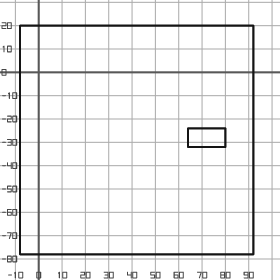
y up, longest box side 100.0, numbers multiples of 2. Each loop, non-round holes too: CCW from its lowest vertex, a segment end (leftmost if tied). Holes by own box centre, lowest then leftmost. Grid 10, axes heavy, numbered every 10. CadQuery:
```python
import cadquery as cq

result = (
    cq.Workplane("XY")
    .moveTo(-8.0, -78.0)
    .lineTo(92.0, -78.0)
    .lineTo(92.0, 20.0)
    .lineTo(-8.0, 20.0)
    .close()
    .moveTo(64.0, -32.0)
    .lineTo(80.0, -32.0)
    .lineTo(80.0, -24.0)
    .lineTo(64.0, -24.0)
    .close()
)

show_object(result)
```